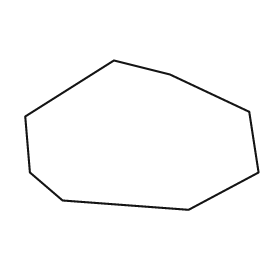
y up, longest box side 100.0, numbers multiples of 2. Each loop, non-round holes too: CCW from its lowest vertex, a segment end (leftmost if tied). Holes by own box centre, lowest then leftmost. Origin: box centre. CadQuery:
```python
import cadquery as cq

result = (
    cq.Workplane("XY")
    .moveTo(20.0, -32.0)
    .lineTo(50.0, -16.0)
    .lineTo(46.0, 10.0)
    .lineTo(12.0, 26.0)
    .lineTo(-12.0, 32.0)
    .lineTo(-50.0, 8.0)
    .lineTo(-48.0, -16.0)
    .lineTo(-34.0, -28.0)
    .close()
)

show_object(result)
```